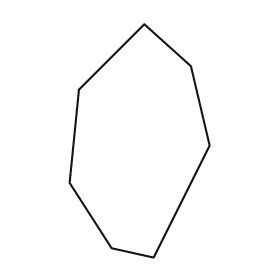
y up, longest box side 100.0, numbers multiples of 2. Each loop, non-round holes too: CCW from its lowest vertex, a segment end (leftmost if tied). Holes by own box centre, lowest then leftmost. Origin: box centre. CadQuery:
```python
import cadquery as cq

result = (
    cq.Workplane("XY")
    .moveTo(6.0, -50.0)
    .lineTo(30.0, -2.0)
    .lineTo(22.0, 32.0)
    .lineTo(2.0, 50.0)
    .lineTo(-26.0, 22.0)
    .lineTo(-30.0, -18.0)
    .lineTo(-12.0, -46.0)
    .close()
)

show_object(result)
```